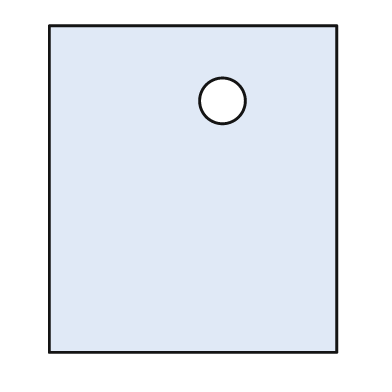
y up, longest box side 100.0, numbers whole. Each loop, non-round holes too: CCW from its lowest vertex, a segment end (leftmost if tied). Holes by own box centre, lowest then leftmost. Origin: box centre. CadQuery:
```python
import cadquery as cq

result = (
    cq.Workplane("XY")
    .moveTo(-44.0, -50.0)
    .lineTo(44.0, -50.0)
    .lineTo(44.0, 50.0)
    .lineTo(-44.0, 50.0)
    .close()
    .moveTo(9.0, 27.0)
    .circle(7.0)
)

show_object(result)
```